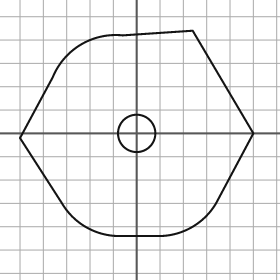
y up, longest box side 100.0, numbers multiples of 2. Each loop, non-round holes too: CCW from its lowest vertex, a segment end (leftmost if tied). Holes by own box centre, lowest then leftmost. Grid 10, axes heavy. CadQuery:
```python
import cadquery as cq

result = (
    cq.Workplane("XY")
    .moveTo(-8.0, -44.0)
    .lineTo(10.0, -44.0)
    .threePointArc((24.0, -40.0), (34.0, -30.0))
    .lineTo(50.0, 0.0)
    .lineTo(24.0, 44.0)
    .lineTo(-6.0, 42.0)
    .threePointArc((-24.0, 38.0), (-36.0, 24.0))
    .lineTo(-50.0, -2.0)
    .lineTo(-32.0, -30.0)
    .threePointArc((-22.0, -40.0), (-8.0, -44.0))
    .close()
    .moveTo(0.0, 0.0)
    .circle(8.0)
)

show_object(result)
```